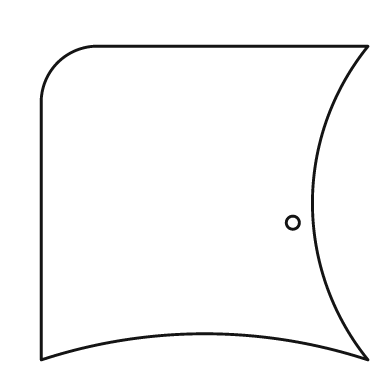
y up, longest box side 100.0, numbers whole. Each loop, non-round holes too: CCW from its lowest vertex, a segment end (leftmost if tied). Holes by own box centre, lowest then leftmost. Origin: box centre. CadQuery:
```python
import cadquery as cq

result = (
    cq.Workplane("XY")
    .moveTo(-50.0, -48.0)
    .threePointArc((0.0, -40.0), (50.0, -48.0))
    .threePointArc((33.0, 0.0), (50.0, 48.0))
    .lineTo(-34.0, 48.0)
    .threePointArc((-45.0, 43.0), (-50.0, 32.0))
    .close()
    .moveTo(27.0, -6.0)
    .circle(2.0)
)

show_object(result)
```